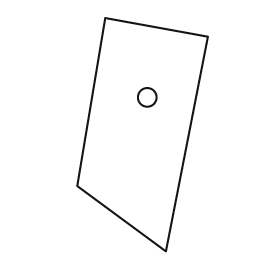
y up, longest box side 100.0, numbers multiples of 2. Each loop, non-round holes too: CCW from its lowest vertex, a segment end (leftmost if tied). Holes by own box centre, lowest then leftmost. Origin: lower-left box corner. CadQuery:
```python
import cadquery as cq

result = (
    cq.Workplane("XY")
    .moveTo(38.0, 0.0)
    .lineTo(56.0, 92.0)
    .lineTo(12.0, 100.0)
    .lineTo(0.0, 28.0)
    .close()
    .moveTo(30.0, 66.0)
    .circle(4.0)
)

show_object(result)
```